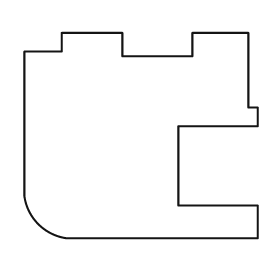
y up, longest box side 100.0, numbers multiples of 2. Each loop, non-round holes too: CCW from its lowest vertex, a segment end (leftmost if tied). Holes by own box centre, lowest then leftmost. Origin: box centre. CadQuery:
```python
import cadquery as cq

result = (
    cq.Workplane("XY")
    .moveTo(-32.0, -44.0)
    .lineTo(50.0, -44.0)
    .lineTo(50.0, -30.0)
    .lineTo(16.0, -30.0)
    .lineTo(16.0, 4.0)
    .lineTo(50.0, 4.0)
    .lineTo(50.0, 12.0)
    .lineTo(46.0, 12.0)
    .lineTo(46.0, 44.0)
    .lineTo(22.0, 44.0)
    .lineTo(22.0, 34.0)
    .lineTo(-8.0, 34.0)
    .lineTo(-8.0, 44.0)
    .lineTo(-34.0, 44.0)
    .lineTo(-34.0, 36.0)
    .lineTo(-50.0, 36.0)
    .lineTo(-50.0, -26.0)
    .threePointArc((-44.0, -38.0), (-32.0, -44.0))
    .close()
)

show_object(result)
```